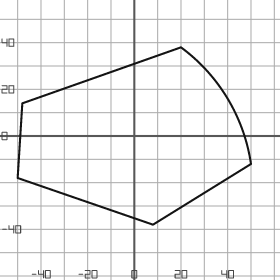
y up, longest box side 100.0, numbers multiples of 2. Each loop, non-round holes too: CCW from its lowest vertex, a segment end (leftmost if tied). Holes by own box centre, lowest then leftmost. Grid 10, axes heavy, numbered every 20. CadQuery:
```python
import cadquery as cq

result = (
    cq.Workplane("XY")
    .moveTo(8.0, -38.0)
    .lineTo(50.0, -12.0)
    .threePointArc((40.0, 16.0), (20.0, 38.0))
    .lineTo(-48.0, 14.0)
    .lineTo(-50.0, -18.0)
    .close()
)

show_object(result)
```